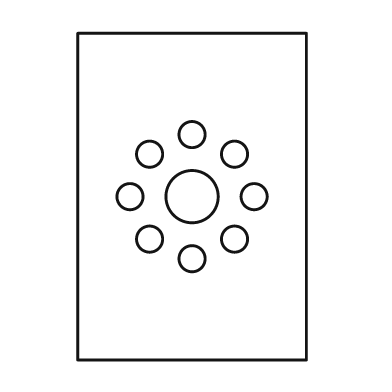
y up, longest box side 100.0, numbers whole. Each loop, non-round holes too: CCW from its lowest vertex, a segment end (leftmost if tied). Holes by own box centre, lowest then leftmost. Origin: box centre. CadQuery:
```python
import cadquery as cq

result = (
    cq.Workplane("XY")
    .moveTo(-35.0, -50.0)
    .lineTo(35.0, -50.0)
    .lineTo(35.0, 50.0)
    .lineTo(-35.0, 50.0)
    .close()
    .moveTo(0.0, -19.0)
    .circle(4.0)
    .moveTo(-13.0, -13.0)
    .circle(4.0)
    .moveTo(13.0, -13.0)
    .circle(4.0)
    .moveTo(-19.0, 0.0)
    .circle(4.0)
    .moveTo(0.0, 0.0)
    .circle(8.0)
    .moveTo(19.0, 0.0)
    .circle(4.0)
    .moveTo(-13.0, 13.0)
    .circle(4.0)
    .moveTo(13.0, 13.0)
    .circle(4.0)
    .moveTo(0.0, 19.0)
    .circle(4.0)
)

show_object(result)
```